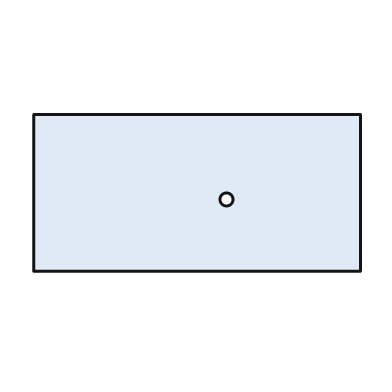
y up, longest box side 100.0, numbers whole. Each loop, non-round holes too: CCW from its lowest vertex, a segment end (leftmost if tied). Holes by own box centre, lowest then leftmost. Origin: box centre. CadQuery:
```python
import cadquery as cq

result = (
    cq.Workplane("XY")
    .moveTo(-50.0, -24.0)
    .lineTo(50.0, -24.0)
    .lineTo(50.0, 24.0)
    .lineTo(-50.0, 24.0)
    .close()
    .moveTo(9.0, -2.0)
    .circle(2.0)
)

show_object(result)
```